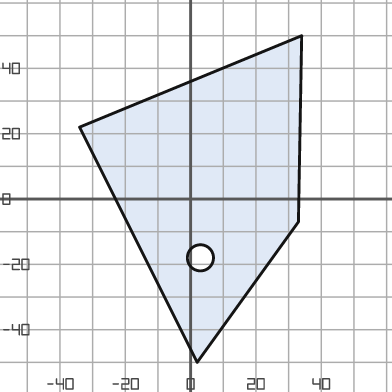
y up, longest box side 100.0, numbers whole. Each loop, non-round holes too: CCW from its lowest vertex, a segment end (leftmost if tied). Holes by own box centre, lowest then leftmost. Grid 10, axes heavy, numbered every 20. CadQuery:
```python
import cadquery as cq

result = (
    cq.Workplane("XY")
    .moveTo(2.0, -50.0)
    .lineTo(33.0, -7.0)
    .lineTo(34.0, 50.0)
    .lineTo(-34.0, 22.0)
    .close()
    .moveTo(3.0, -18.0)
    .circle(4.0)
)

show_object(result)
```